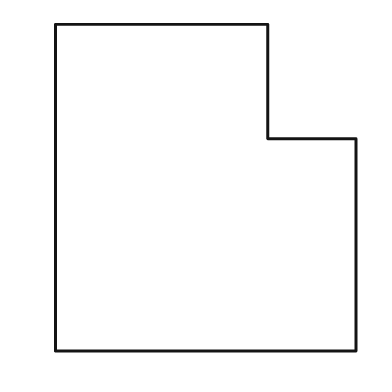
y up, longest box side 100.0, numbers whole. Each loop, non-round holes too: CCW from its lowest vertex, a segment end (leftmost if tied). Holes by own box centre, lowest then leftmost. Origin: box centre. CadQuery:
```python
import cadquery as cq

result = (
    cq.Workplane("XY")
    .moveTo(-46.0, -50.0)
    .lineTo(46.0, -50.0)
    .lineTo(46.0, 15.0)
    .lineTo(19.0, 15.0)
    .lineTo(19.0, 50.0)
    .lineTo(-46.0, 50.0)
    .close()
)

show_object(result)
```